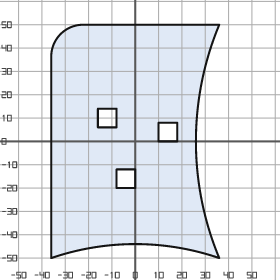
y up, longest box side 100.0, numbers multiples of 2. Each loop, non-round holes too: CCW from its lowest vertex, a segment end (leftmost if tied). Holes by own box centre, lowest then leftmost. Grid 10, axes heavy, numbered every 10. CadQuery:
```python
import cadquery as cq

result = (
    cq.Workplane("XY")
    .moveTo(-36.0, -50.0)
    .threePointArc((0.0, -44.0), (36.0, -50.0))
    .threePointArc((26.0, 0.0), (36.0, 50.0))
    .lineTo(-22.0, 50.0)
    .threePointArc((-32.0, 46.0), (-36.0, 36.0))
    .close()
    .moveTo(-8.0, -20.0)
    .lineTo(0.0, -20.0)
    .lineTo(0.0, -12.0)
    .lineTo(-8.0, -12.0)
    .close()
    .moveTo(10.0, 0.0)
    .lineTo(18.0, 0.0)
    .lineTo(18.0, 8.0)
    .lineTo(10.0, 8.0)
    .close()
    .moveTo(-16.0, 6.0)
    .lineTo(-8.0, 6.0)
    .lineTo(-8.0, 14.0)
    .lineTo(-16.0, 14.0)
    .close()
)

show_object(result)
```